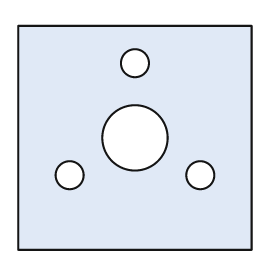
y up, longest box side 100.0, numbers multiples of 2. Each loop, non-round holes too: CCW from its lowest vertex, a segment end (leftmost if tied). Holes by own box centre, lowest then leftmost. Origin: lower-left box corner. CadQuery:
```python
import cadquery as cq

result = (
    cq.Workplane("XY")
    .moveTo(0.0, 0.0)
    .lineTo(100.0, 0.0)
    .lineTo(100.0, 96.0)
    .lineTo(0.0, 96.0)
    .close()
    .moveTo(22.0, 32.0)
    .circle(6.0)
    .moveTo(78.0, 32.0)
    .circle(6.0)
    .moveTo(50.0, 48.0)
    .circle(14.0)
    .moveTo(50.0, 80.0)
    .circle(6.0)
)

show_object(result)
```